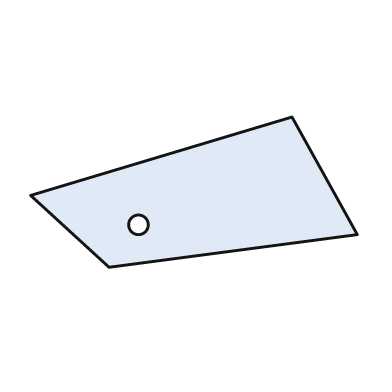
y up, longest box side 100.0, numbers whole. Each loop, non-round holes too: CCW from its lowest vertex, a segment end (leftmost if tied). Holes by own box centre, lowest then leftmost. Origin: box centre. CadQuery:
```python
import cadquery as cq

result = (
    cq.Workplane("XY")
    .moveTo(-26.0, -23.0)
    .lineTo(50.0, -13.0)
    .lineTo(30.0, 23.0)
    .lineTo(-50.0, -1.0)
    .close()
    .moveTo(-17.0, -10.0)
    .circle(3.0)
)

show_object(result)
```